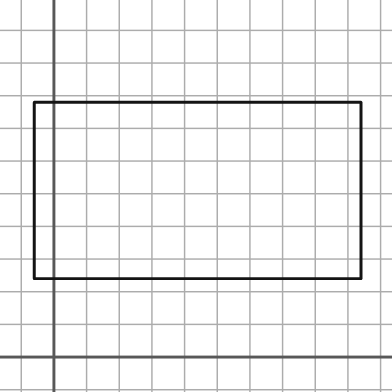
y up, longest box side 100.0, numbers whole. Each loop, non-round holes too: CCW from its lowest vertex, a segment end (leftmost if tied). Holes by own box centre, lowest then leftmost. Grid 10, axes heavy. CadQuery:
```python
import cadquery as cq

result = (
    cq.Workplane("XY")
    .moveTo(-6.0, 24.0)
    .lineTo(94.0, 24.0)
    .lineTo(94.0, 78.0)
    .lineTo(-6.0, 78.0)
    .close()
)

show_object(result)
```